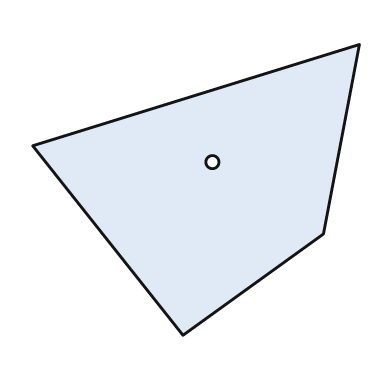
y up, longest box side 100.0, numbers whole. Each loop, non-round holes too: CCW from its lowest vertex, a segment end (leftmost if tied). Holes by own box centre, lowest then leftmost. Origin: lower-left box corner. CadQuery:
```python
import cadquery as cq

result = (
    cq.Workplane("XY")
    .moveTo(46.0, 0.0)
    .lineTo(89.0, 31.0)
    .lineTo(100.0, 89.0)
    .lineTo(0.0, 58.0)
    .close()
    .moveTo(55.0, 53.0)
    .circle(2.0)
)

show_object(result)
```